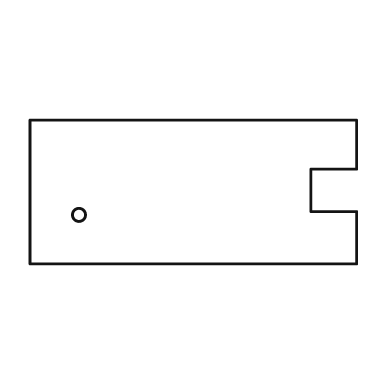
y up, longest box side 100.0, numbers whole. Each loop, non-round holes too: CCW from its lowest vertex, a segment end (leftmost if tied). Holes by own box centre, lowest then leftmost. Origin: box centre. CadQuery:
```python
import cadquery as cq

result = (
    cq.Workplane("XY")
    .moveTo(-50.0, -22.0)
    .lineTo(50.0, -22.0)
    .lineTo(50.0, -6.0)
    .lineTo(36.0, -6.0)
    .lineTo(36.0, 7.0)
    .lineTo(50.0, 7.0)
    .lineTo(50.0, 22.0)
    .lineTo(-50.0, 22.0)
    .close()
    .moveTo(-35.0, -7.0)
    .circle(2.0)
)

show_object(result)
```